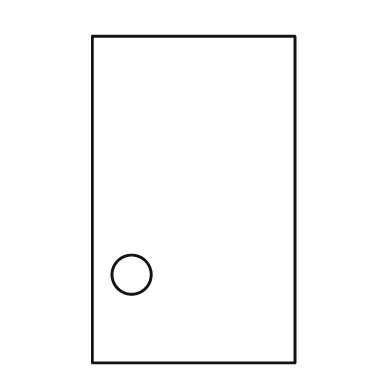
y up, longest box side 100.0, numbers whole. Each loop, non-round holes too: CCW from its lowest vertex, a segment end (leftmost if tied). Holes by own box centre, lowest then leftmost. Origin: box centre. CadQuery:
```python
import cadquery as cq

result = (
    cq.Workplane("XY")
    .moveTo(-31.0, -50.0)
    .lineTo(31.0, -50.0)
    .lineTo(31.0, 50.0)
    .lineTo(-31.0, 50.0)
    .close()
    .moveTo(-19.0, -23.0)
    .circle(6.0)
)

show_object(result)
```